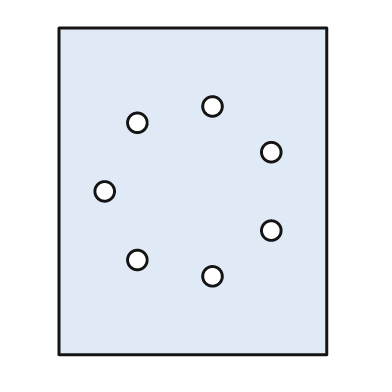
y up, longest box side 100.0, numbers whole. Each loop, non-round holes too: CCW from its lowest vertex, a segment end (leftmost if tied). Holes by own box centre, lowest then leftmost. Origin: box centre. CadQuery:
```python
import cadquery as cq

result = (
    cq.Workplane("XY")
    .moveTo(-41.0, -50.0)
    .lineTo(41.0, -50.0)
    .lineTo(41.0, 50.0)
    .lineTo(-41.0, 50.0)
    .close()
    .moveTo(6.0, -26.0)
    .circle(3.0)
    .moveTo(-17.0, -21.0)
    .circle(3.0)
    .moveTo(24.0, -12.0)
    .circle(3.0)
    .moveTo(-27.0, 0.0)
    .circle(3.0)
    .moveTo(24.0, 12.0)
    .circle(3.0)
    .moveTo(-17.0, 21.0)
    .circle(3.0)
    .moveTo(6.0, 26.0)
    .circle(3.0)
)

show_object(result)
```